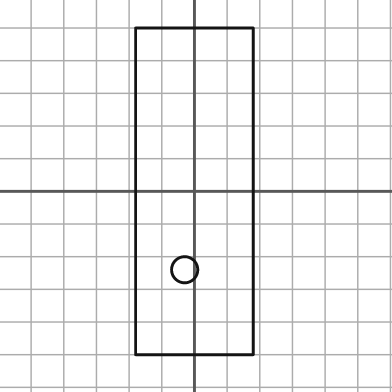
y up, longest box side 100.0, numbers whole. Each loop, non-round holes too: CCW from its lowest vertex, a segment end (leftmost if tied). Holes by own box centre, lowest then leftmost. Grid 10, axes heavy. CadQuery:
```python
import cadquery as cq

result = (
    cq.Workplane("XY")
    .moveTo(-18.0, -50.0)
    .lineTo(18.0, -50.0)
    .lineTo(18.0, 50.0)
    .lineTo(-18.0, 50.0)
    .close()
    .moveTo(-3.0, -24.0)
    .circle(4.0)
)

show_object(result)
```